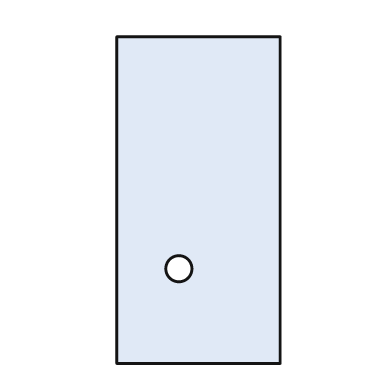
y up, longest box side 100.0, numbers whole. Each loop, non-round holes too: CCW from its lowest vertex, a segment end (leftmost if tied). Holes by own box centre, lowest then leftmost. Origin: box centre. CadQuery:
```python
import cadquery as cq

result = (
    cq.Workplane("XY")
    .moveTo(-25.0, -50.0)
    .lineTo(25.0, -50.0)
    .lineTo(25.0, 50.0)
    .lineTo(-25.0, 50.0)
    .close()
    .moveTo(-6.0, -21.0)
    .circle(4.0)
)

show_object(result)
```